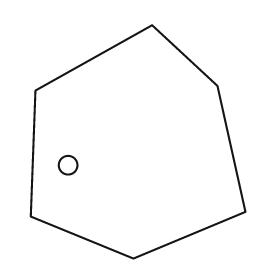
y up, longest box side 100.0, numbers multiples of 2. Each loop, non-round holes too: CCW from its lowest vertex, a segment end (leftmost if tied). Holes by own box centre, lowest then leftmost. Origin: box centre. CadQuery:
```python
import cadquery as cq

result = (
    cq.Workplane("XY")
    .moveTo(-2.0, -50.0)
    .lineTo(46.0, -30.0)
    .lineTo(34.0, 24.0)
    .lineTo(6.0, 50.0)
    .lineTo(-44.0, 22.0)
    .lineTo(-46.0, -32.0)
    .close()
    .moveTo(-30.0, -10.0)
    .circle(4.0)
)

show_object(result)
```